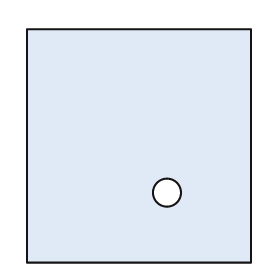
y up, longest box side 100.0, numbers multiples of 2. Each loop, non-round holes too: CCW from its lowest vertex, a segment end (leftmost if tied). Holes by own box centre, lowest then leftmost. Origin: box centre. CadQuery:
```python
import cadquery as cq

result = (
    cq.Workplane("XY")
    .moveTo(-48.0, -50.0)
    .lineTo(48.0, -50.0)
    .lineTo(48.0, 50.0)
    .lineTo(-48.0, 50.0)
    .close()
    .moveTo(12.0, -20.0)
    .circle(6.0)
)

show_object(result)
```